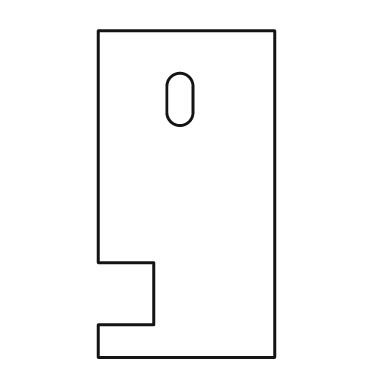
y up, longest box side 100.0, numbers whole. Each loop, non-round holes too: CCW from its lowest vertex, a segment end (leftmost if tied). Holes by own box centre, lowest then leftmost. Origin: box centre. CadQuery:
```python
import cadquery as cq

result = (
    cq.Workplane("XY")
    .moveTo(-27.0, -50.0)
    .lineTo(27.0, -50.0)
    .lineTo(27.0, 50.0)
    .lineTo(-27.0, 50.0)
    .lineTo(-27.0, -21.0)
    .lineTo(-10.0, -21.0)
    .lineTo(-10.0, -40.0)
    .lineTo(-27.0, -40.0)
    .close()
    .moveTo(-6.0, 25.0)
    .threePointArc((-2.0, 21.0), (2.0, 25.0))
    .lineTo(2.0, 33.0)
    .threePointArc((-2.0, 37.0), (-6.0, 33.0))
    .close()
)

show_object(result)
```